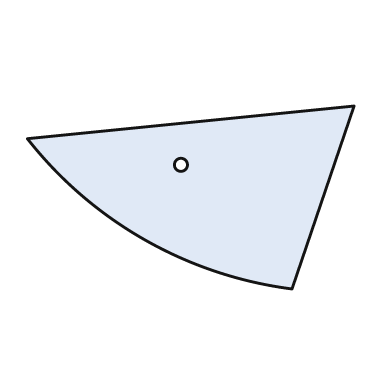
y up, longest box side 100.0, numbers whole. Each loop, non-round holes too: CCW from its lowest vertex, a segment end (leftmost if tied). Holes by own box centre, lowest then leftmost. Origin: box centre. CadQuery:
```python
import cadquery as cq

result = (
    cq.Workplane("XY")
    .moveTo(31.0, -28.0)
    .lineTo(50.0, 28.0)
    .lineTo(-50.0, 18.0)
    .threePointArc((-14.0, -13.0), (31.0, -28.0))
    .close()
    .moveTo(-3.0, 10.0)
    .circle(2.0)
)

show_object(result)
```